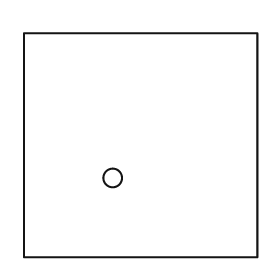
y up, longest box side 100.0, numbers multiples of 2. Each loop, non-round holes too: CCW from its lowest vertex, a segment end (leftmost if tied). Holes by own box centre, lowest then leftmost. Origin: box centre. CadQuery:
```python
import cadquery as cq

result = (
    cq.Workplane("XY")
    .moveTo(-50.0, -48.0)
    .lineTo(50.0, -48.0)
    .lineTo(50.0, 48.0)
    .lineTo(-50.0, 48.0)
    .close()
    .moveTo(-12.0, -14.0)
    .circle(4.0)
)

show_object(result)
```